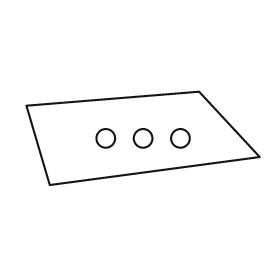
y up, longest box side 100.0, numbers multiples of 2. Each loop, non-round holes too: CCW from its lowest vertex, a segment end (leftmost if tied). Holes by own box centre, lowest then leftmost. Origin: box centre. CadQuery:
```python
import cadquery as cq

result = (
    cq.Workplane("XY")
    .moveTo(-40.0, -20.0)
    .lineTo(50.0, -8.0)
    .lineTo(24.0, 20.0)
    .lineTo(-50.0, 14.0)
    .close()
    .moveTo(-16.0, 0.0)
    .circle(4.0)
    .moveTo(0.0, 0.0)
    .circle(4.0)
    .moveTo(16.0, 0.0)
    .circle(4.0)
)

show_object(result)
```